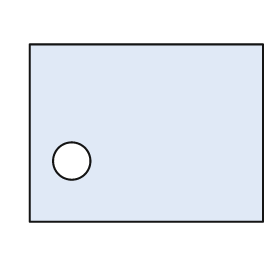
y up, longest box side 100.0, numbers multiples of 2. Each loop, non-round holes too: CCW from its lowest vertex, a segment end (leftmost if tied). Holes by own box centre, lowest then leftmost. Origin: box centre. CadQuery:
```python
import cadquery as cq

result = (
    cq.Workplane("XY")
    .moveTo(-50.0, -38.0)
    .lineTo(50.0, -38.0)
    .lineTo(50.0, 38.0)
    .lineTo(-50.0, 38.0)
    .close()
    .moveTo(-32.0, -12.0)
    .circle(8.0)
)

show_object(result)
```